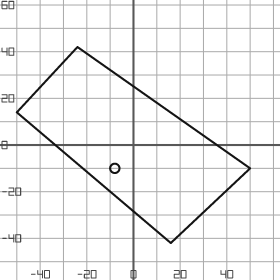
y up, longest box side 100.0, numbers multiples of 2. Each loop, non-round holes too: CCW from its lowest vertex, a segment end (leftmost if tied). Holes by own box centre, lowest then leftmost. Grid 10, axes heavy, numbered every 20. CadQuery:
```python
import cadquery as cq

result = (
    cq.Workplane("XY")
    .moveTo(16.0, -42.0)
    .lineTo(50.0, -10.0)
    .lineTo(-24.0, 42.0)
    .lineTo(-50.0, 14.0)
    .close()
    .moveTo(-8.0, -10.0)
    .circle(2.0)
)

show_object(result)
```